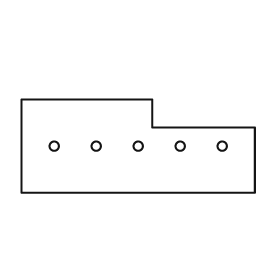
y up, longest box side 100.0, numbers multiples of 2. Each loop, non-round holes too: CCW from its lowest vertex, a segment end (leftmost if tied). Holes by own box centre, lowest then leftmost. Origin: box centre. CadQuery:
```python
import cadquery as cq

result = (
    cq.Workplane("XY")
    .moveTo(-50.0, -20.0)
    .lineTo(50.0, -20.0)
    .lineTo(50.0, 8.0)
    .lineTo(6.0, 8.0)
    .lineTo(6.0, 20.0)
    .lineTo(-50.0, 20.0)
    .close()
    .moveTo(-36.0, 0.0)
    .circle(2.0)
    .moveTo(-18.0, 0.0)
    .circle(2.0)
    .moveTo(0.0, 0.0)
    .circle(2.0)
    .moveTo(18.0, 0.0)
    .circle(2.0)
    .moveTo(36.0, 0.0)
    .circle(2.0)
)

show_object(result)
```